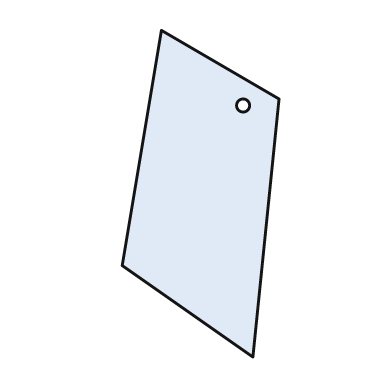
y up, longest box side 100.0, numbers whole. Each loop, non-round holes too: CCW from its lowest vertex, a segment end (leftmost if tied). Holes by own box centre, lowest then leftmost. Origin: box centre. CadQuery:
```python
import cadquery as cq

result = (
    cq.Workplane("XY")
    .moveTo(16.0, -50.0)
    .lineTo(24.0, 29.0)
    .lineTo(-12.0, 50.0)
    .lineTo(-24.0, -22.0)
    .close()
    .moveTo(13.0, 27.0)
    .circle(2.0)
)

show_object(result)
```